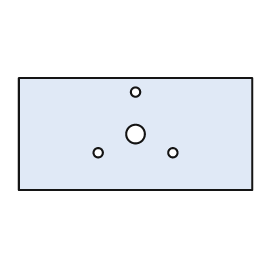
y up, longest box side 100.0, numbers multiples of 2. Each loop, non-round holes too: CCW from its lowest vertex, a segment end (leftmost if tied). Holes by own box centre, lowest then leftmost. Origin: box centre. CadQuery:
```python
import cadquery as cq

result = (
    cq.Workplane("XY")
    .moveTo(-50.0, -24.0)
    .lineTo(50.0, -24.0)
    .lineTo(50.0, 24.0)
    .lineTo(-50.0, 24.0)
    .close()
    .moveTo(-16.0, -8.0)
    .circle(2.0)
    .moveTo(16.0, -8.0)
    .circle(2.0)
    .moveTo(0.0, 0.0)
    .circle(4.0)
    .moveTo(0.0, 18.0)
    .circle(2.0)
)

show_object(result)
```